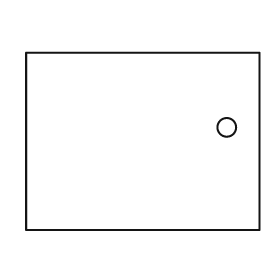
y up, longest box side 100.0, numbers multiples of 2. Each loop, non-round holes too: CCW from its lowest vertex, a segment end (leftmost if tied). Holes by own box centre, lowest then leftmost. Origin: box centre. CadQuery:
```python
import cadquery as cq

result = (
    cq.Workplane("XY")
    .moveTo(-50.0, -38.0)
    .lineTo(50.0, -38.0)
    .lineTo(50.0, 38.0)
    .lineTo(-50.0, 38.0)
    .close()
    .moveTo(36.0, 6.0)
    .circle(4.0)
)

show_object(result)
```